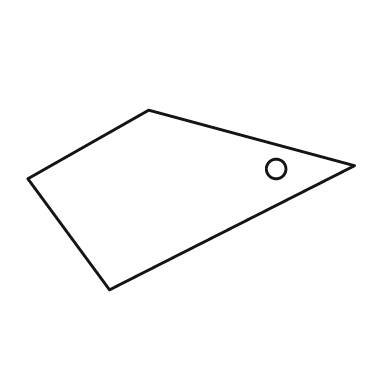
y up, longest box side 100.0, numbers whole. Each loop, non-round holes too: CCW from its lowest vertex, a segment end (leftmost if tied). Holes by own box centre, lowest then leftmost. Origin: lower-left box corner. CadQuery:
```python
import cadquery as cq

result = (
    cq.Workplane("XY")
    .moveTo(25.0, 0.0)
    .lineTo(100.0, 38.0)
    .lineTo(37.0, 55.0)
    .lineTo(0.0, 34.0)
    .close()
    .moveTo(76.0, 37.0)
    .circle(3.0)
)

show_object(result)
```